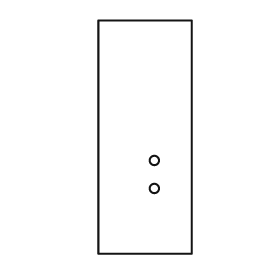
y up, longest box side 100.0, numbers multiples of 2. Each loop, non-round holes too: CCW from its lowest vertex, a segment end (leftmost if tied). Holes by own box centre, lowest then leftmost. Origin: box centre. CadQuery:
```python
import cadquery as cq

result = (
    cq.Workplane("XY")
    .moveTo(-20.0, -50.0)
    .lineTo(20.0, -50.0)
    .lineTo(20.0, 50.0)
    .lineTo(-20.0, 50.0)
    .close()
    .moveTo(4.0, -22.0)
    .circle(2.0)
    .moveTo(4.0, -10.0)
    .circle(2.0)
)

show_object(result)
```